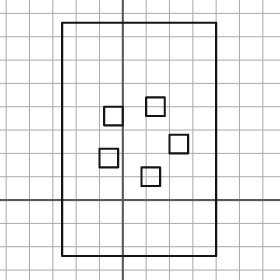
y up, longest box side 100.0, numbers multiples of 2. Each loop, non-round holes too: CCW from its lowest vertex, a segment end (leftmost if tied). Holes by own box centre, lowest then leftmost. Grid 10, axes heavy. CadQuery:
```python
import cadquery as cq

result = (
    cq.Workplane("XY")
    .moveTo(-26.0, -24.0)
    .lineTo(40.0, -24.0)
    .lineTo(40.0, 76.0)
    .lineTo(-26.0, 76.0)
    .close()
    .moveTo(8.0, 6.0)
    .lineTo(16.0, 6.0)
    .lineTo(16.0, 14.0)
    .lineTo(8.0, 14.0)
    .close()
    .moveTo(-10.0, 14.0)
    .lineTo(-2.0, 14.0)
    .lineTo(-2.0, 22.0)
    .lineTo(-10.0, 22.0)
    .close()
    .moveTo(20.0, 20.0)
    .lineTo(28.0, 20.0)
    .lineTo(28.0, 28.0)
    .lineTo(20.0, 28.0)
    .close()
    .moveTo(-8.0, 32.0)
    .lineTo(0.0, 32.0)
    .lineTo(0.0, 40.0)
    .lineTo(-8.0, 40.0)
    .close()
    .moveTo(10.0, 36.0)
    .lineTo(18.0, 36.0)
    .lineTo(18.0, 44.0)
    .lineTo(10.0, 44.0)
    .close()
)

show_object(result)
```